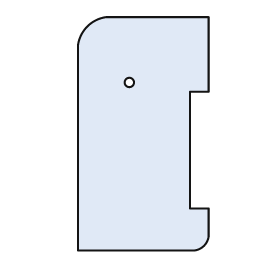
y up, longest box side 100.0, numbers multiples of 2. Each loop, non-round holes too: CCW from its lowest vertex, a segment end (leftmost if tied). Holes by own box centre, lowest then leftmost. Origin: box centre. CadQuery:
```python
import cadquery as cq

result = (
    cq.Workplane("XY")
    .moveTo(-28.0, -50.0)
    .lineTo(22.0, -50.0)
    .threePointArc((26.0, -48.0), (28.0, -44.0))
    .lineTo(28.0, -32.0)
    .lineTo(20.0, -32.0)
    .lineTo(20.0, 18.0)
    .lineTo(28.0, 18.0)
    .lineTo(28.0, 50.0)
    .lineTo(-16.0, 50.0)
    .threePointArc((-24.0, 46.0), (-28.0, 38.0))
    .close()
    .moveTo(-6.0, 22.0)
    .circle(2.0)
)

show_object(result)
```